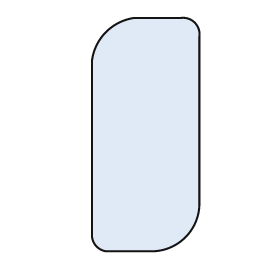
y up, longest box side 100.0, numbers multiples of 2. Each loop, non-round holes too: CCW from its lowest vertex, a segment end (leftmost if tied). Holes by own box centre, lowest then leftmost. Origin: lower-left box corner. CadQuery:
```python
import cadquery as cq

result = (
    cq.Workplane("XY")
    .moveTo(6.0, 0.0)
    .lineTo(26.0, 0.0)
    .threePointArc((40.0, 6.0), (46.0, 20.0))
    .lineTo(46.0, 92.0)
    .threePointArc((44.0, 98.0), (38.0, 100.0))
    .lineTo(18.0, 100.0)
    .threePointArc((6.0, 94.0), (0.0, 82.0))
    .lineTo(0.0, 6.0)
    .threePointArc((2.0, 2.0), (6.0, 0.0))
    .close()
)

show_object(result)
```